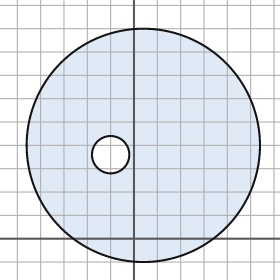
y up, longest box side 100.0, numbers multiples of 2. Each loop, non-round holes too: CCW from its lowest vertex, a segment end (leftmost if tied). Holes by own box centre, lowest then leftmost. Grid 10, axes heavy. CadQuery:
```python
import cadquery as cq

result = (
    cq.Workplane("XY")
    .moveTo(4.0, 40.0)
    .circle(50.0)
    .moveTo(-10.0, 36.0)
    .circle(8.0)
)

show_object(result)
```